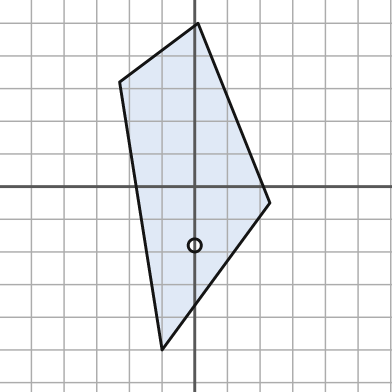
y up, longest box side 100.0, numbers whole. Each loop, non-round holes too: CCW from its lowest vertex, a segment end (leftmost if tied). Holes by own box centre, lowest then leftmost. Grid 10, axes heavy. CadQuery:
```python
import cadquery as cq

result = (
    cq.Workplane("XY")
    .moveTo(-10.0, -50.0)
    .lineTo(23.0, -5.0)
    .lineTo(1.0, 50.0)
    .lineTo(-23.0, 32.0)
    .close()
    .moveTo(0.0, -18.0)
    .circle(2.0)
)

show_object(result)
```